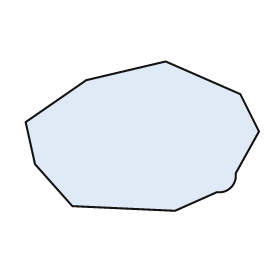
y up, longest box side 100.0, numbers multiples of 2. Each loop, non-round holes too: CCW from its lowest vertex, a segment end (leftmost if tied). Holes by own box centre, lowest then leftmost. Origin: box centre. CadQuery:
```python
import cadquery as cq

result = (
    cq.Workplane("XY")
    .moveTo(14.0, -32.0)
    .lineTo(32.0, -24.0)
    .threePointArc((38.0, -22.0), (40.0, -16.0))
    .lineTo(50.0, 2.0)
    .lineTo(42.0, 18.0)
    .lineTo(10.0, 32.0)
    .lineTo(-24.0, 24.0)
    .lineTo(-50.0, 6.0)
    .lineTo(-46.0, -12.0)
    .lineTo(-30.0, -30.0)
    .close()
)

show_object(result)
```